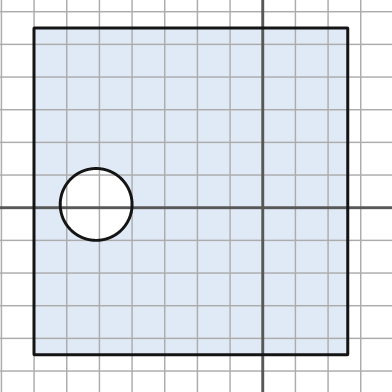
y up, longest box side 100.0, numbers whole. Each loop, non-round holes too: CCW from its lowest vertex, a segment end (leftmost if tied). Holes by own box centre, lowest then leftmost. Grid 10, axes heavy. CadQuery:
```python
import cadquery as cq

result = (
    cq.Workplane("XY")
    .moveTo(-70.0, -45.0)
    .lineTo(26.0, -45.0)
    .lineTo(26.0, 55.0)
    .lineTo(-70.0, 55.0)
    .close()
    .moveTo(-51.0, 1.0)
    .circle(11.0)
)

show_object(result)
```